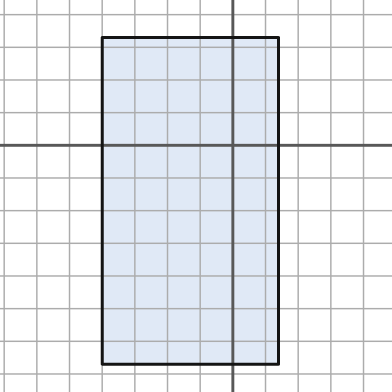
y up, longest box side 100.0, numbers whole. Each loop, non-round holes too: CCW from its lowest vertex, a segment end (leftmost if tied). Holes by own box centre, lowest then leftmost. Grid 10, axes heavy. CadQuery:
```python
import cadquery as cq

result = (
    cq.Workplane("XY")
    .moveTo(-40.0, -67.0)
    .lineTo(14.0, -67.0)
    .lineTo(14.0, 33.0)
    .lineTo(-40.0, 33.0)
    .close()
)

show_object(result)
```